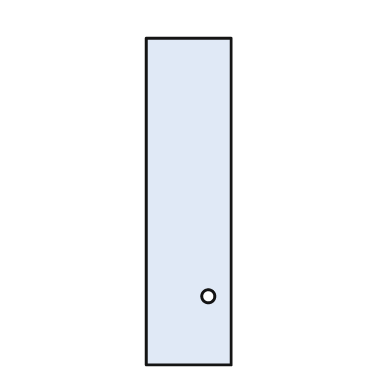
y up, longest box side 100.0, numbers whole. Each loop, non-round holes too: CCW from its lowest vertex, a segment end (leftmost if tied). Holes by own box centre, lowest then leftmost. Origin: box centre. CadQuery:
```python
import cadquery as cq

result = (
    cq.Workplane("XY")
    .moveTo(-13.0, -50.0)
    .lineTo(13.0, -50.0)
    .lineTo(13.0, 50.0)
    .lineTo(-13.0, 50.0)
    .close()
    .moveTo(6.0, -29.0)
    .circle(2.0)
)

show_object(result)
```